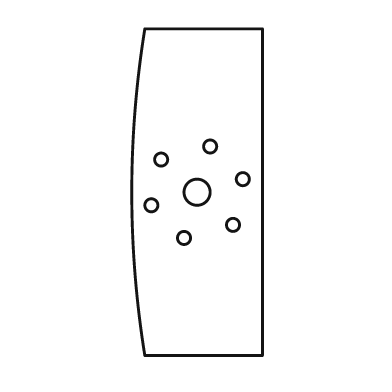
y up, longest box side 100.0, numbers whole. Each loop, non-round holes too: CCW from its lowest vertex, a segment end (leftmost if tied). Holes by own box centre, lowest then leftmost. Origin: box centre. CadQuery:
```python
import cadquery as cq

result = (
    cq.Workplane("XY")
    .moveTo(-16.0, -50.0)
    .lineTo(20.0, -50.0)
    .lineTo(20.0, 50.0)
    .lineTo(-16.0, 50.0)
    .threePointArc((-20.0, 0.0), (-16.0, -50.0))
    .close()
    .moveTo(-4.0, -14.0)
    .circle(2.0)
    .moveTo(11.0, -10.0)
    .circle(2.0)
    .moveTo(-14.0, -4.0)
    .circle(2.0)
    .moveTo(0.0, 0.0)
    .circle(4.0)
    .moveTo(14.0, 4.0)
    .circle(2.0)
    .moveTo(-11.0, 10.0)
    .circle(2.0)
    .moveTo(4.0, 14.0)
    .circle(2.0)
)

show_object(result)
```